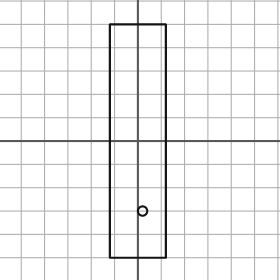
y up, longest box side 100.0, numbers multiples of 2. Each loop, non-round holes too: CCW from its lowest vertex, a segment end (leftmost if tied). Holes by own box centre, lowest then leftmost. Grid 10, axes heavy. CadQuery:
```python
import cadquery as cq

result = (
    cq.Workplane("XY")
    .moveTo(-12.0, -50.0)
    .lineTo(12.0, -50.0)
    .lineTo(12.0, 50.0)
    .lineTo(-12.0, 50.0)
    .close()
    .moveTo(2.0, -30.0)
    .circle(2.0)
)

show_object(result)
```